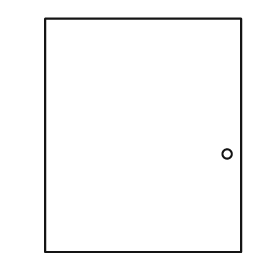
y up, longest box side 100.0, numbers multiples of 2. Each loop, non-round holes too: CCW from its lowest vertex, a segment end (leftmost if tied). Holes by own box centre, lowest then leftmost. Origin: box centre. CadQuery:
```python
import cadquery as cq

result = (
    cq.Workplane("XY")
    .moveTo(-42.0, -50.0)
    .lineTo(42.0, -50.0)
    .lineTo(42.0, 50.0)
    .lineTo(-42.0, 50.0)
    .close()
    .moveTo(36.0, -8.0)
    .circle(2.0)
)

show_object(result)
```